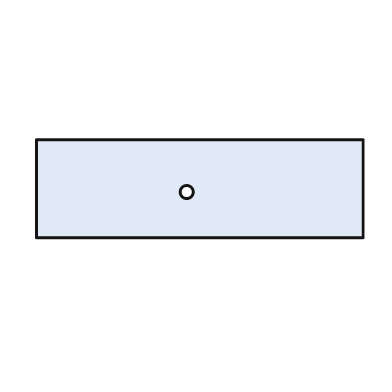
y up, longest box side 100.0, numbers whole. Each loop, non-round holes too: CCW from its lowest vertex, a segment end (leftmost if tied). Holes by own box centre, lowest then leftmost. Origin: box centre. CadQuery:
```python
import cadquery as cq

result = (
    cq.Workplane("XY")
    .moveTo(-50.0, -15.0)
    .lineTo(50.0, -15.0)
    .lineTo(50.0, 15.0)
    .lineTo(-50.0, 15.0)
    .close()
    .moveTo(-4.0, -1.0)
    .circle(2.0)
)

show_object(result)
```